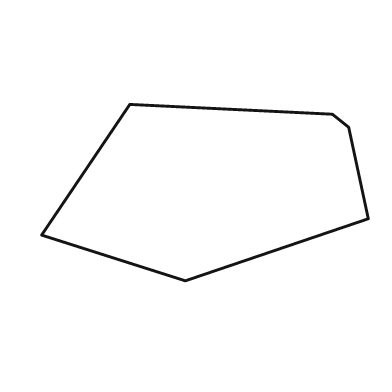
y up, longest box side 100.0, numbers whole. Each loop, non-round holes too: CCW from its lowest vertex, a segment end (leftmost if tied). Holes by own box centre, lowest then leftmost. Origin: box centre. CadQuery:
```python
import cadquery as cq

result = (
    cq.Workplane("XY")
    .moveTo(-6.0, -27.0)
    .lineTo(50.0, -8.0)
    .lineTo(44.0, 20.0)
    .lineTo(39.0, 24.0)
    .lineTo(-23.0, 27.0)
    .lineTo(-50.0, -13.0)
    .close()
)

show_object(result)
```